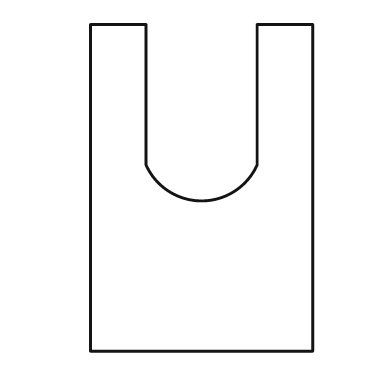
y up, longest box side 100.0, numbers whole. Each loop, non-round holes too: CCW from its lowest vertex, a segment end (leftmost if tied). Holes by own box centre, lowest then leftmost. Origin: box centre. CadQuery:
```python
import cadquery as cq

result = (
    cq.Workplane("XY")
    .moveTo(-34.0, -50.0)
    .lineTo(34.0, -50.0)
    .lineTo(34.0, 50.0)
    .lineTo(17.0, 50.0)
    .lineTo(17.0, 7.0)
    .threePointArc((0.0, -4.0), (-17.0, 7.0))
    .lineTo(-17.0, 50.0)
    .lineTo(-34.0, 50.0)
    .close()
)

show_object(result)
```